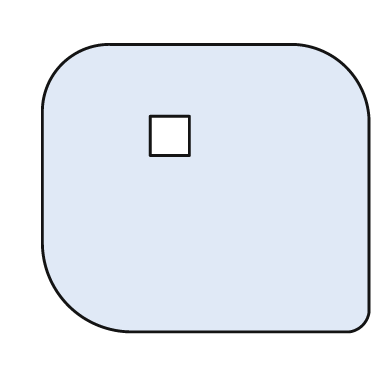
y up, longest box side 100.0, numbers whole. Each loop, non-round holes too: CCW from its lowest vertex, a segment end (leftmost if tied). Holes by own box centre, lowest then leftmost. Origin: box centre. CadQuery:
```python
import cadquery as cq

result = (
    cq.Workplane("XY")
    .moveTo(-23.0, -44.0)
    .lineTo(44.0, -44.0)
    .threePointArc((48.0, -42.0), (50.0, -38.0))
    .lineTo(50.0, 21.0)
    .threePointArc((43.0, 37.0), (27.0, 44.0))
    .lineTo(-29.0, 44.0)
    .threePointArc((-44.0, 38.0), (-50.0, 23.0))
    .lineTo(-50.0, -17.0)
    .threePointArc((-42.0, -36.0), (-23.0, -44.0))
    .close()
    .moveTo(-17.0, 10.0)
    .lineTo(-5.0, 10.0)
    .lineTo(-5.0, 22.0)
    .lineTo(-17.0, 22.0)
    .close()
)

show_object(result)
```